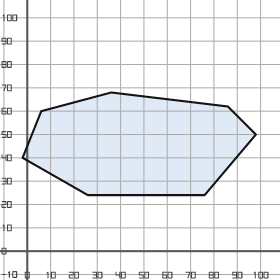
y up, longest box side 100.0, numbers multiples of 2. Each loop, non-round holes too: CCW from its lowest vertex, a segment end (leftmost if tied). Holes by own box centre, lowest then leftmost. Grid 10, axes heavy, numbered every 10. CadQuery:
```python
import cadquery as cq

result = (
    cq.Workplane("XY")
    .moveTo(26.0, 24.0)
    .lineTo(76.0, 24.0)
    .lineTo(98.0, 50.0)
    .lineTo(86.0, 62.0)
    .lineTo(36.0, 68.0)
    .lineTo(6.0, 60.0)
    .lineTo(-2.0, 40.0)
    .close()
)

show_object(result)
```